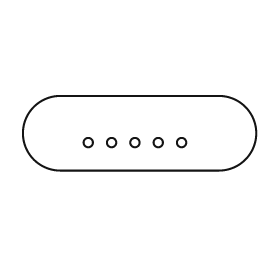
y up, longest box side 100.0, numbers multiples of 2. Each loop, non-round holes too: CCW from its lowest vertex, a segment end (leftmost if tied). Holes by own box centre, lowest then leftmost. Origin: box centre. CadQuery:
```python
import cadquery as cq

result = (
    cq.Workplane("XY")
    .moveTo(-34.0, -16.0)
    .lineTo(34.0, -16.0)
    .threePointArc((50.0, 0.0), (34.0, 16.0))
    .lineTo(-34.0, 16.0)
    .threePointArc((-50.0, 0.0), (-34.0, -16.0))
    .close()
    .moveTo(-22.0, -4.0)
    .circle(2.0)
    .moveTo(-12.0, -4.0)
    .circle(2.0)
    .moveTo(-2.0, -4.0)
    .circle(2.0)
    .moveTo(8.0, -4.0)
    .circle(2.0)
    .moveTo(18.0, -4.0)
    .circle(2.0)
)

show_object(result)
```